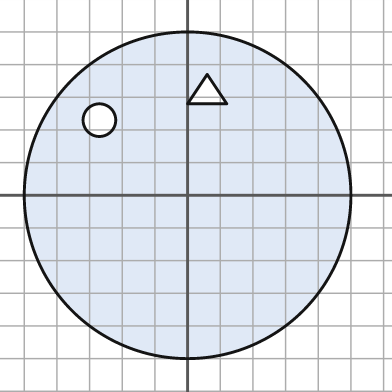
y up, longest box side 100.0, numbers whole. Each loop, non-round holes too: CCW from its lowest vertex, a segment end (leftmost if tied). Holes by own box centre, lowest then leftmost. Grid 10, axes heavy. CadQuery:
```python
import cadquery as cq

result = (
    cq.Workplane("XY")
    .moveTo(0.0, 0.0)
    .circle(50.0)
    .moveTo(-27.0, 23.0)
    .circle(5.0)
    .moveTo(0.0, 28.0)
    .lineTo(12.0, 28.0)
    .lineTo(6.0, 37.0)
    .close()
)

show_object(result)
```